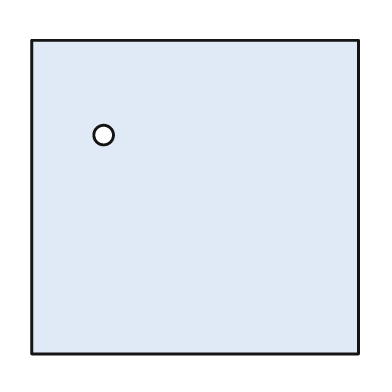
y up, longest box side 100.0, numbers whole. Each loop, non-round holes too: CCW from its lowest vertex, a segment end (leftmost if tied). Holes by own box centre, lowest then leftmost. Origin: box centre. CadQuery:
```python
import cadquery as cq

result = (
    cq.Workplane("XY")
    .moveTo(-50.0, -48.0)
    .lineTo(50.0, -48.0)
    .lineTo(50.0, 48.0)
    .lineTo(-50.0, 48.0)
    .close()
    .moveTo(-28.0, 19.0)
    .circle(3.0)
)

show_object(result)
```